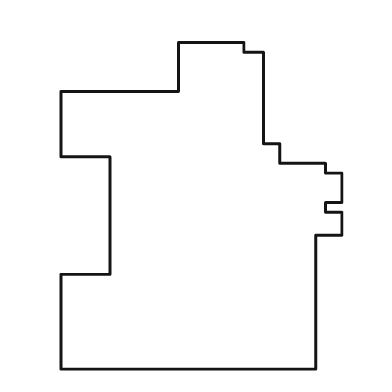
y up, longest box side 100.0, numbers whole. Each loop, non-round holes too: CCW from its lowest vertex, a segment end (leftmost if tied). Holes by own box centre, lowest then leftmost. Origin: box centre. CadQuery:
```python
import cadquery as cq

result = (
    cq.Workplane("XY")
    .moveTo(-43.0, -50.0)
    .lineTo(35.0, -50.0)
    .lineTo(35.0, -9.0)
    .lineTo(43.0, -9.0)
    .lineTo(43.0, -2.0)
    .lineTo(38.0, -2.0)
    .lineTo(38.0, 1.0)
    .lineTo(43.0, 1.0)
    .lineTo(43.0, 10.0)
    .lineTo(38.0, 10.0)
    .lineTo(38.0, 13.0)
    .lineTo(24.0, 13.0)
    .lineTo(24.0, 19.0)
    .lineTo(19.0, 19.0)
    .lineTo(19.0, 47.0)
    .lineTo(13.0, 47.0)
    .lineTo(13.0, 50.0)
    .lineTo(-7.0, 50.0)
    .lineTo(-7.0, 35.0)
    .lineTo(-43.0, 35.0)
    .lineTo(-43.0, 15.0)
    .lineTo(-28.0, 15.0)
    .lineTo(-28.0, -21.0)
    .lineTo(-43.0, -21.0)
    .close()
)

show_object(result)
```